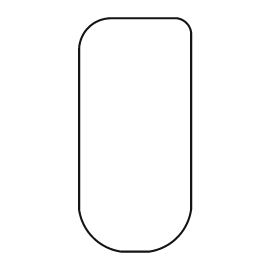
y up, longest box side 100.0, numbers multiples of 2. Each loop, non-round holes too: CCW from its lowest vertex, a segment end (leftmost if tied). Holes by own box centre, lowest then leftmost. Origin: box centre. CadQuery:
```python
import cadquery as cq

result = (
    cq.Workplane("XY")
    .moveTo(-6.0, -50.0)
    .lineTo(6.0, -50.0)
    .threePointArc((18.0, -44.0), (24.0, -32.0))
    .lineTo(24.0, 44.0)
    .threePointArc((22.0, 48.0), (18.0, 50.0))
    .lineTo(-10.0, 50.0)
    .threePointArc((-20.0, 46.0), (-24.0, 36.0))
    .lineTo(-24.0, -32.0)
    .threePointArc((-18.0, -44.0), (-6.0, -50.0))
    .close()
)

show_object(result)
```